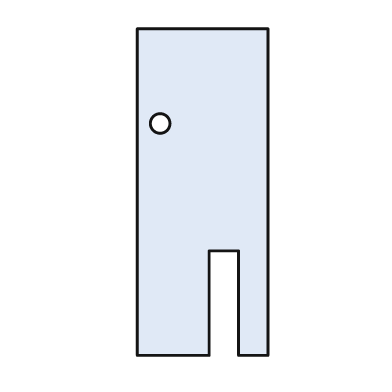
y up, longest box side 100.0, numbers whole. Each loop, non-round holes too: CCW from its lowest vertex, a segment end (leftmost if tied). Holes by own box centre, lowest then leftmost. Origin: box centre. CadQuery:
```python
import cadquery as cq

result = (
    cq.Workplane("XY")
    .moveTo(-20.0, -50.0)
    .lineTo(2.0, -50.0)
    .lineTo(2.0, -18.0)
    .lineTo(11.0, -18.0)
    .lineTo(11.0, -50.0)
    .lineTo(20.0, -50.0)
    .lineTo(20.0, 50.0)
    .lineTo(-20.0, 50.0)
    .close()
    .moveTo(-13.0, 21.0)
    .circle(3.0)
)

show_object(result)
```